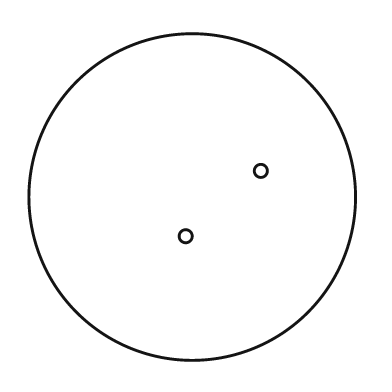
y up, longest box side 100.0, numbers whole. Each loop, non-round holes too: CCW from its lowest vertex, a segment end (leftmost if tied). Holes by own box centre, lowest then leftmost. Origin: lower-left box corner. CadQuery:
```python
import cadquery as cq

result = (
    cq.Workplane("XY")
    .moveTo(50.0, 50.0)
    .circle(50.0)
    .moveTo(48.0, 38.0)
    .circle(2.0)
    .moveTo(71.0, 58.0)
    .circle(2.0)
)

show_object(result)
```